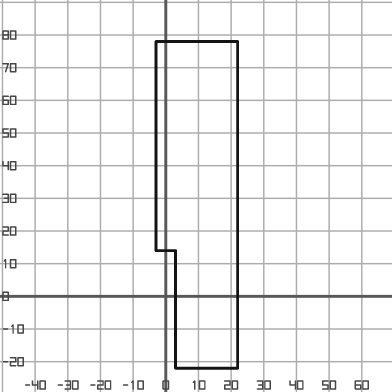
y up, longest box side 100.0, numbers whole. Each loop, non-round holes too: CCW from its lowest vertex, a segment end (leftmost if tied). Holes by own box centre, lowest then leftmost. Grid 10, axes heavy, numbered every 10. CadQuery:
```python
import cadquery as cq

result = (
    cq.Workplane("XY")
    .moveTo(3.0, -22.0)
    .lineTo(22.0, -22.0)
    .lineTo(22.0, 78.0)
    .lineTo(-3.0, 78.0)
    .lineTo(-3.0, 14.0)
    .lineTo(3.0, 14.0)
    .close()
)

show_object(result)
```